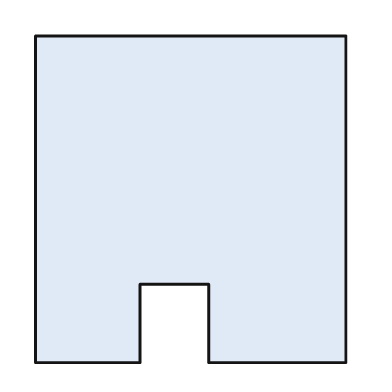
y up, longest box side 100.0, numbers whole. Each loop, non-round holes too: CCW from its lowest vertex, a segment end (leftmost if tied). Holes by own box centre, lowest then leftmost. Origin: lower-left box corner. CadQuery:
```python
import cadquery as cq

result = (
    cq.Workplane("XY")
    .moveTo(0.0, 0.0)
    .lineTo(32.0, 0.0)
    .lineTo(32.0, 24.0)
    .lineTo(53.0, 24.0)
    .lineTo(53.0, 0.0)
    .lineTo(95.0, 0.0)
    .lineTo(95.0, 100.0)
    .lineTo(0.0, 100.0)
    .close()
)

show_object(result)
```